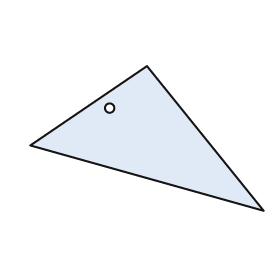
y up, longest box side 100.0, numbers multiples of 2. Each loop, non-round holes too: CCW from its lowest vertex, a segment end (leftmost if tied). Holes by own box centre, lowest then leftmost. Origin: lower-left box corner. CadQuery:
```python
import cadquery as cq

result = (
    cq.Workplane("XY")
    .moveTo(100.0, 0.0)
    .lineTo(50.0, 62.0)
    .lineTo(0.0, 28.0)
    .close()
    .moveTo(34.0, 44.0)
    .circle(2.0)
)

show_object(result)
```